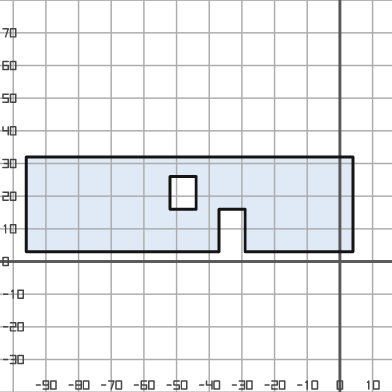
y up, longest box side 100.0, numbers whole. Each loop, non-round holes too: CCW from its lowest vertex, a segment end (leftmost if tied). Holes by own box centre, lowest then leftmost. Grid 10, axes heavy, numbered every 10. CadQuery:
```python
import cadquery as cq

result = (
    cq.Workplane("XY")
    .moveTo(-96.0, 3.0)
    .lineTo(-37.0, 3.0)
    .lineTo(-37.0, 16.0)
    .lineTo(-29.0, 16.0)
    .lineTo(-29.0, 3.0)
    .lineTo(4.0, 3.0)
    .lineTo(4.0, 32.0)
    .lineTo(-96.0, 32.0)
    .close()
    .moveTo(-52.0, 16.0)
    .lineTo(-44.0, 16.0)
    .lineTo(-44.0, 26.0)
    .lineTo(-52.0, 26.0)
    .close()
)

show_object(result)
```